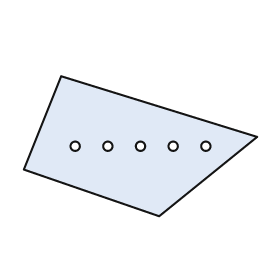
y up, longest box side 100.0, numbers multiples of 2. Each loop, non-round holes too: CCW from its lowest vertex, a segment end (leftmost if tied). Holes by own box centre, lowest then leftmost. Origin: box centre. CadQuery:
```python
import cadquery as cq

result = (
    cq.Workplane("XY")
    .moveTo(8.0, -30.0)
    .lineTo(50.0, 4.0)
    .lineTo(-34.0, 30.0)
    .lineTo(-50.0, -10.0)
    .close()
    .moveTo(-28.0, 0.0)
    .circle(2.0)
    .moveTo(-14.0, 0.0)
    .circle(2.0)
    .moveTo(0.0, 0.0)
    .circle(2.0)
    .moveTo(14.0, 0.0)
    .circle(2.0)
    .moveTo(28.0, 0.0)
    .circle(2.0)
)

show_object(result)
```